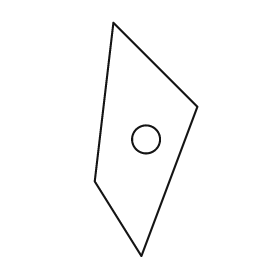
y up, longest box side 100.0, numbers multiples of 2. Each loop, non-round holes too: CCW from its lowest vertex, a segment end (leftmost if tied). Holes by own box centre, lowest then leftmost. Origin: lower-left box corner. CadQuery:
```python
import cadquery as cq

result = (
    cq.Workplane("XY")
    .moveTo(20.0, 0.0)
    .lineTo(44.0, 64.0)
    .lineTo(8.0, 100.0)
    .lineTo(0.0, 32.0)
    .close()
    .moveTo(22.0, 50.0)
    .circle(6.0)
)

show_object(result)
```